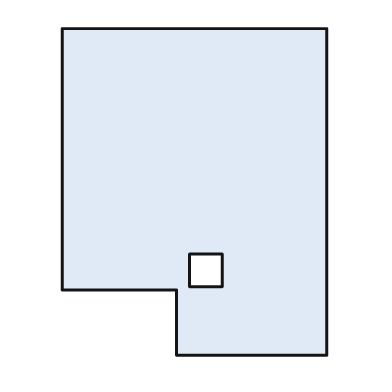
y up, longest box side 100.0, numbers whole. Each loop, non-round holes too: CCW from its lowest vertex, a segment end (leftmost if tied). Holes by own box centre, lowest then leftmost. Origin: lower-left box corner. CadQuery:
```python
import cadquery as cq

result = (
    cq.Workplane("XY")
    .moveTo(35.0, 0.0)
    .lineTo(81.0, 0.0)
    .lineTo(81.0, 100.0)
    .lineTo(0.0, 100.0)
    .lineTo(0.0, 20.0)
    .lineTo(35.0, 20.0)
    .close()
    .moveTo(39.0, 21.0)
    .lineTo(49.0, 21.0)
    .lineTo(49.0, 31.0)
    .lineTo(39.0, 31.0)
    .close()
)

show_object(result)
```